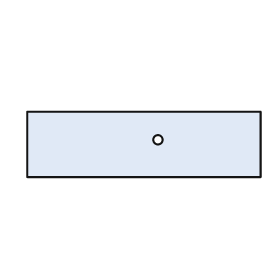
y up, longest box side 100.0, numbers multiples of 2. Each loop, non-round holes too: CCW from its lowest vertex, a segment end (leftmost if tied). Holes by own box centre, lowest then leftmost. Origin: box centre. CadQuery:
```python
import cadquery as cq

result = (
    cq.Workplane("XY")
    .moveTo(-50.0, -14.0)
    .lineTo(50.0, -14.0)
    .lineTo(50.0, 14.0)
    .lineTo(-50.0, 14.0)
    .close()
    .moveTo(6.0, 2.0)
    .circle(2.0)
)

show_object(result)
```